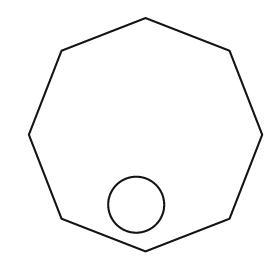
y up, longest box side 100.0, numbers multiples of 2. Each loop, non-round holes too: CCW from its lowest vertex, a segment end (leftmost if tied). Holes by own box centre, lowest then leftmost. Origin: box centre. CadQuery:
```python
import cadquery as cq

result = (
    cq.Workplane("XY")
    .moveTo(0.0, -50.0)
    .lineTo(36.0, -36.0)
    .lineTo(50.0, 0.0)
    .lineTo(36.0, 36.0)
    .lineTo(0.0, 50.0)
    .lineTo(-36.0, 36.0)
    .lineTo(-50.0, 0.0)
    .lineTo(-36.0, -36.0)
    .close()
    .moveTo(-4.0, -30.0)
    .circle(12.0)
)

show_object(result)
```